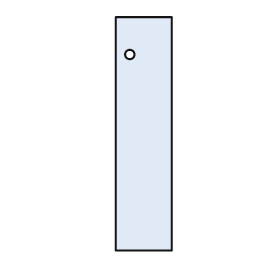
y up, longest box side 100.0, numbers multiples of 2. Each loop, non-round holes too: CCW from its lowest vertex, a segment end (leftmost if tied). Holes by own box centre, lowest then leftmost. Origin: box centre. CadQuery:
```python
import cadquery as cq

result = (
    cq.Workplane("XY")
    .moveTo(-12.0, -50.0)
    .lineTo(12.0, -50.0)
    .lineTo(12.0, 50.0)
    .lineTo(-12.0, 50.0)
    .close()
    .moveTo(-6.0, 34.0)
    .circle(2.0)
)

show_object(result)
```